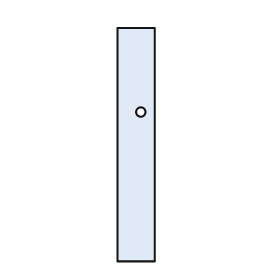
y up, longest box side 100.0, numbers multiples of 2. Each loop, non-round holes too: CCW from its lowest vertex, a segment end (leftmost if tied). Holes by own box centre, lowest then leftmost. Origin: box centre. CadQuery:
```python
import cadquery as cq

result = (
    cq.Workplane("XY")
    .moveTo(-8.0, -50.0)
    .lineTo(8.0, -50.0)
    .lineTo(8.0, 50.0)
    .lineTo(-8.0, 50.0)
    .close()
    .moveTo(2.0, 14.0)
    .circle(2.0)
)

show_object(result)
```